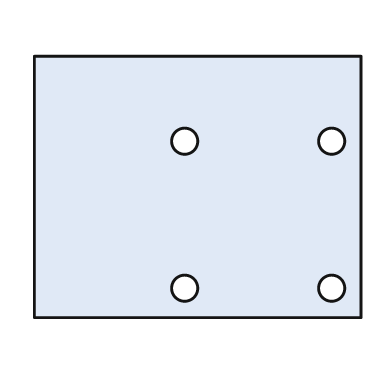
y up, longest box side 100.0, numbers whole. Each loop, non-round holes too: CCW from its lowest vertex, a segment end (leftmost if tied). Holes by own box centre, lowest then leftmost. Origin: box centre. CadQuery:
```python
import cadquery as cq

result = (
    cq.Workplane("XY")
    .moveTo(-50.0, -40.0)
    .lineTo(50.0, -40.0)
    .lineTo(50.0, 40.0)
    .lineTo(-50.0, 40.0)
    .close()
    .moveTo(-4.0, -31.0)
    .circle(4.0)
    .moveTo(41.0, -31.0)
    .circle(4.0)
    .moveTo(-4.0, 14.0)
    .circle(4.0)
    .moveTo(41.0, 14.0)
    .circle(4.0)
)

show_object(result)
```